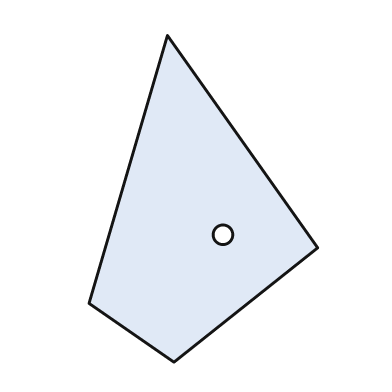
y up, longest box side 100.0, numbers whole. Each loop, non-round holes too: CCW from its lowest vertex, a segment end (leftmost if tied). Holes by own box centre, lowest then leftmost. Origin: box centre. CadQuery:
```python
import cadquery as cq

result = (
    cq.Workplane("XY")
    .moveTo(-9.0, -50.0)
    .lineTo(35.0, -15.0)
    .lineTo(-11.0, 50.0)
    .lineTo(-35.0, -32.0)
    .close()
    .moveTo(6.0, -11.0)
    .circle(3.0)
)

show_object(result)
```